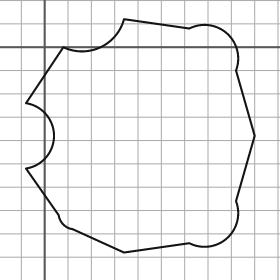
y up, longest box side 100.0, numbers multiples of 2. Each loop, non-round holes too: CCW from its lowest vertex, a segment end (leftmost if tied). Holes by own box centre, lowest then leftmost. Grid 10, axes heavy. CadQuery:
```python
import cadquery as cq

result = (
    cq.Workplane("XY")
    .moveTo(34.0, -88.0)
    .lineTo(62.0, -84.0)
    .threePointArc((78.0, -82.0), (82.0, -66.0))
    .lineTo(90.0, -38.0)
    .lineTo(82.0, -10.0)
    .threePointArc((78.0, 6.0), (62.0, 8.0))
    .lineTo(34.0, 12.0)
    .threePointArc((24.0, 0.0), (8.0, 0.0))
    .lineTo(-8.0, -24.0)
    .threePointArc((4.0, -38.0), (-8.0, -52.0))
    .lineTo(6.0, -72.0)
    .threePointArc((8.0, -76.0), (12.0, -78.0))
    .close()
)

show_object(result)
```